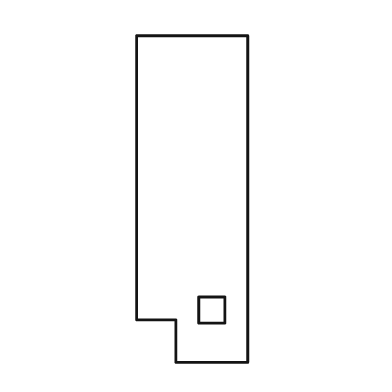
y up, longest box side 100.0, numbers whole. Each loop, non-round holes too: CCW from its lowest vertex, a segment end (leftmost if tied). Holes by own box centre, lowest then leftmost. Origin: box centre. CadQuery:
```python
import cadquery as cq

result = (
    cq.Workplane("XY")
    .moveTo(-5.0, -50.0)
    .lineTo(17.0, -50.0)
    .lineTo(17.0, 50.0)
    .lineTo(-17.0, 50.0)
    .lineTo(-17.0, -37.0)
    .lineTo(-5.0, -37.0)
    .close()
    .moveTo(2.0, -38.0)
    .lineTo(10.0, -38.0)
    .lineTo(10.0, -30.0)
    .lineTo(2.0, -30.0)
    .close()
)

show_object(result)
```